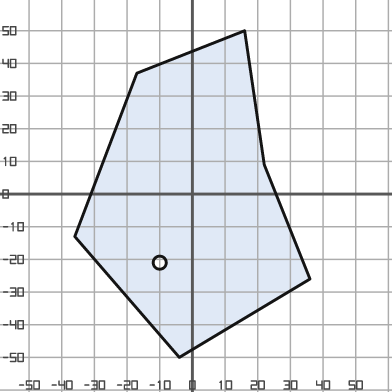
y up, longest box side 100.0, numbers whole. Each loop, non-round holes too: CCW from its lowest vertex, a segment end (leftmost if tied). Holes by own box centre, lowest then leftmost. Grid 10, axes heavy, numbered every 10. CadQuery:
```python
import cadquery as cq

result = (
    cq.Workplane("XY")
    .moveTo(-4.0, -50.0)
    .lineTo(36.0, -26.0)
    .lineTo(22.0, 9.0)
    .lineTo(16.0, 50.0)
    .lineTo(-17.0, 37.0)
    .lineTo(-36.0, -13.0)
    .close()
    .moveTo(-10.0, -21.0)
    .circle(2.0)
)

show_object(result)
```